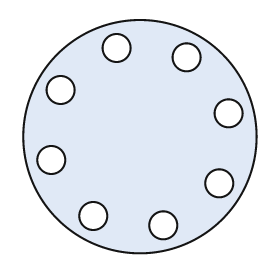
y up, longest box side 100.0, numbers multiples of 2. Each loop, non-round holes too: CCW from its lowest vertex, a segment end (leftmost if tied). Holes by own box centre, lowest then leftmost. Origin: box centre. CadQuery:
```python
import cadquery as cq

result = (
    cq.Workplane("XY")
    .moveTo(0.0, 0.0)
    .circle(50.0)
    .moveTo(10.0, -38.0)
    .circle(6.0)
    .moveTo(-20.0, -34.0)
    .circle(6.0)
    .moveTo(34.0, -20.0)
    .circle(6.0)
    .moveTo(-38.0, -10.0)
    .circle(6.0)
    .moveTo(38.0, 10.0)
    .circle(6.0)
    .moveTo(-34.0, 20.0)
    .circle(6.0)
    .moveTo(20.0, 34.0)
    .circle(6.0)
    .moveTo(-10.0, 38.0)
    .circle(6.0)
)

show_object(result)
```